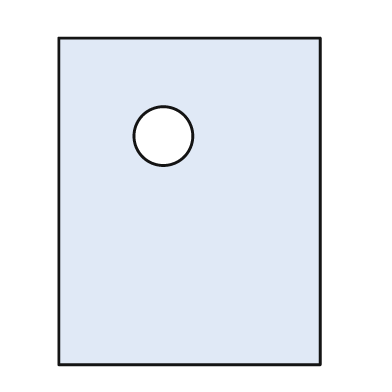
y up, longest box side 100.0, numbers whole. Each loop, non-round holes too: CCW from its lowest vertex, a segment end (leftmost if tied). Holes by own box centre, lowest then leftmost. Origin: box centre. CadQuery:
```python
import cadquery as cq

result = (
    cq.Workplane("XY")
    .moveTo(-40.0, -50.0)
    .lineTo(40.0, -50.0)
    .lineTo(40.0, 50.0)
    .lineTo(-40.0, 50.0)
    .close()
    .moveTo(-8.0, 20.0)
    .circle(9.0)
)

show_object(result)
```